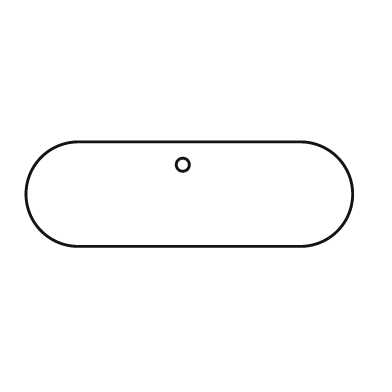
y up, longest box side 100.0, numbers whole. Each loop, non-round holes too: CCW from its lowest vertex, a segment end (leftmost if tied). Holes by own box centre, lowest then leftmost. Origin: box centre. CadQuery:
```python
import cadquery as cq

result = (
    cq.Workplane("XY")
    .moveTo(-34.0, -16.0)
    .lineTo(34.0, -16.0)
    .threePointArc((50.0, 0.0), (34.0, 16.0))
    .lineTo(-34.0, 16.0)
    .threePointArc((-50.0, 0.0), (-34.0, -16.0))
    .close()
    .moveTo(-2.0, 9.0)
    .circle(2.0)
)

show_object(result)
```